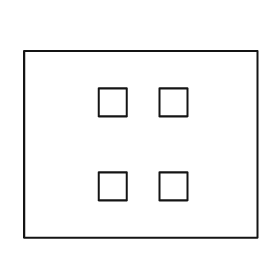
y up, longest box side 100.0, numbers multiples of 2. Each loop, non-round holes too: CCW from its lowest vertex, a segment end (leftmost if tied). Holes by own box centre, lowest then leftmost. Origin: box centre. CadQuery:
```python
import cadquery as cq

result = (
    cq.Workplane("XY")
    .moveTo(-50.0, -40.0)
    .lineTo(50.0, -40.0)
    .lineTo(50.0, 40.0)
    .lineTo(-50.0, 40.0)
    .close()
    .moveTo(-18.0, -24.0)
    .lineTo(-6.0, -24.0)
    .lineTo(-6.0, -12.0)
    .lineTo(-18.0, -12.0)
    .close()
    .moveTo(8.0, -24.0)
    .lineTo(20.0, -24.0)
    .lineTo(20.0, -12.0)
    .lineTo(8.0, -12.0)
    .close()
    .moveTo(-18.0, 12.0)
    .lineTo(-6.0, 12.0)
    .lineTo(-6.0, 24.0)
    .lineTo(-18.0, 24.0)
    .close()
    .moveTo(8.0, 12.0)
    .lineTo(20.0, 12.0)
    .lineTo(20.0, 24.0)
    .lineTo(8.0, 24.0)
    .close()
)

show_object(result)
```